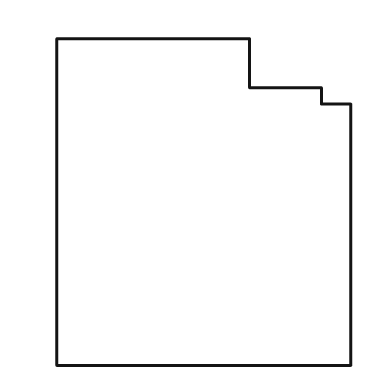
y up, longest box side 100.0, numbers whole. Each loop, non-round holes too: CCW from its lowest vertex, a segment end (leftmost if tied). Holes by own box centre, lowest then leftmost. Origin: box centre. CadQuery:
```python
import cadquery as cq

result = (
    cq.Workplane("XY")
    .moveTo(-45.0, -50.0)
    .lineTo(45.0, -50.0)
    .lineTo(45.0, 30.0)
    .lineTo(36.0, 30.0)
    .lineTo(36.0, 35.0)
    .lineTo(14.0, 35.0)
    .lineTo(14.0, 50.0)
    .lineTo(-45.0, 50.0)
    .close()
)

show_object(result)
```